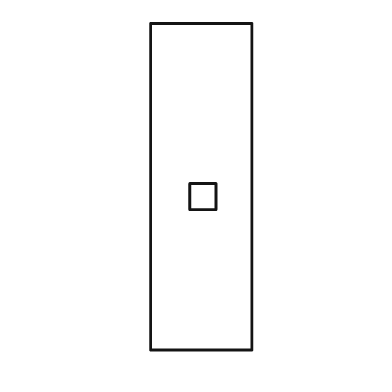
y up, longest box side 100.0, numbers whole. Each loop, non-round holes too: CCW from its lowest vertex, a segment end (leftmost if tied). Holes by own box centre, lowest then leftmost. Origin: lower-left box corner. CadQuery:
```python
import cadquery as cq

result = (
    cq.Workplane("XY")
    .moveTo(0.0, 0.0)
    .lineTo(31.0, 0.0)
    .lineTo(31.0, 100.0)
    .lineTo(0.0, 100.0)
    .close()
    .moveTo(12.0, 43.0)
    .lineTo(20.0, 43.0)
    .lineTo(20.0, 51.0)
    .lineTo(12.0, 51.0)
    .close()
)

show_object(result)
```